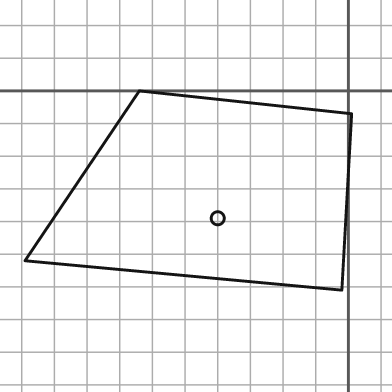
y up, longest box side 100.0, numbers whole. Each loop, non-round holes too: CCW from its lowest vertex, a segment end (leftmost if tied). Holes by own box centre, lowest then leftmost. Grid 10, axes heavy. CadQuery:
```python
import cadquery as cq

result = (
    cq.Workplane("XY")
    .moveTo(-2.0, -61.0)
    .lineTo(1.0, -7.0)
    .lineTo(-64.0, 0.0)
    .lineTo(-99.0, -52.0)
    .close()
    .moveTo(-40.0, -39.0)
    .circle(2.0)
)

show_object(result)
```